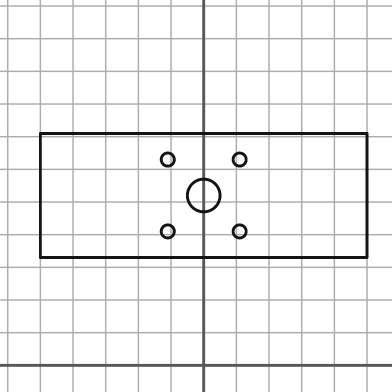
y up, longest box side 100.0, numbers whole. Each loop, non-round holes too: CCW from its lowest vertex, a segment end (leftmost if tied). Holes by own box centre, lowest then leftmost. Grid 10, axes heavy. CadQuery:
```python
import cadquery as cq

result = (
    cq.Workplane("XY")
    .moveTo(-50.0, 33.0)
    .lineTo(50.0, 33.0)
    .lineTo(50.0, 71.0)
    .lineTo(-50.0, 71.0)
    .close()
    .moveTo(-11.0, 41.0)
    .circle(2.0)
    .moveTo(11.0, 41.0)
    .circle(2.0)
    .moveTo(0.0, 52.0)
    .circle(5.0)
    .moveTo(-11.0, 63.0)
    .circle(2.0)
    .moveTo(11.0, 63.0)
    .circle(2.0)
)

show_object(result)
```